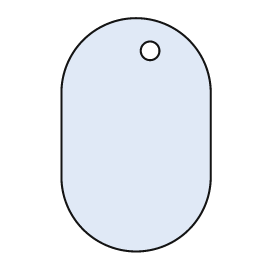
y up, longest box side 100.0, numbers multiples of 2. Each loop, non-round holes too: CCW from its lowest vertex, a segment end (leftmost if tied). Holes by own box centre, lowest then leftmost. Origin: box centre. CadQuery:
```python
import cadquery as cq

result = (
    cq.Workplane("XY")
    .moveTo(-32.0, -18.0)
    .threePointArc((0.0, -50.0), (32.0, -18.0))
    .lineTo(32.0, 18.0)
    .threePointArc((0.0, 50.0), (-32.0, 18.0))
    .close()
    .moveTo(6.0, 36.0)
    .circle(4.0)
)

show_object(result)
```